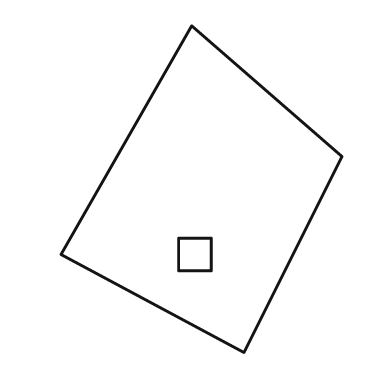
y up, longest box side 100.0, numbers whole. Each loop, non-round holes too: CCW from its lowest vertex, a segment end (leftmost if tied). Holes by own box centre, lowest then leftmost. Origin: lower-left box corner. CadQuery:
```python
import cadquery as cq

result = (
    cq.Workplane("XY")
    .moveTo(56.0, 0.0)
    .lineTo(86.0, 60.0)
    .lineTo(40.0, 100.0)
    .lineTo(0.0, 30.0)
    .close()
    .moveTo(36.0, 25.0)
    .lineTo(46.0, 25.0)
    .lineTo(46.0, 35.0)
    .lineTo(36.0, 35.0)
    .close()
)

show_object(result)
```